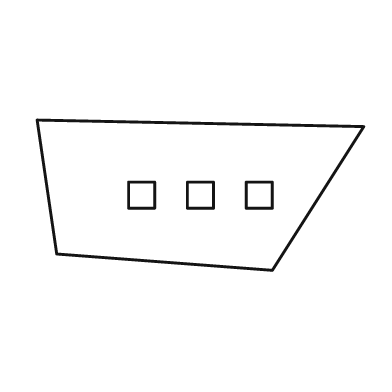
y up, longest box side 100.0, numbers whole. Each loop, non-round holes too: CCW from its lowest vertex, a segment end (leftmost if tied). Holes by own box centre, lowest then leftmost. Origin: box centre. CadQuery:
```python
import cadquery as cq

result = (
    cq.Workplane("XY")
    .moveTo(22.0, -23.0)
    .lineTo(50.0, 21.0)
    .lineTo(-50.0, 23.0)
    .lineTo(-44.0, -18.0)
    .close()
    .moveTo(-22.0, -4.0)
    .lineTo(-14.0, -4.0)
    .lineTo(-14.0, 4.0)
    .lineTo(-22.0, 4.0)
    .close()
    .moveTo(-4.0, -4.0)
    .lineTo(4.0, -4.0)
    .lineTo(4.0, 4.0)
    .lineTo(-4.0, 4.0)
    .close()
    .moveTo(14.0, -4.0)
    .lineTo(22.0, -4.0)
    .lineTo(22.0, 4.0)
    .lineTo(14.0, 4.0)
    .close()
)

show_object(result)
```